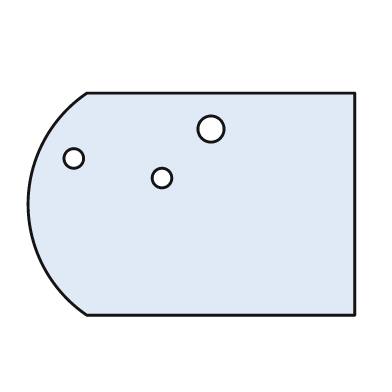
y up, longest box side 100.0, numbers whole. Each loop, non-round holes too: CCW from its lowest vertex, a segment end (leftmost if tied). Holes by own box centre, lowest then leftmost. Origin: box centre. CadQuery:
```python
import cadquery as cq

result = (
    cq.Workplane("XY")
    .moveTo(-32.0, -34.0)
    .lineTo(50.0, -34.0)
    .lineTo(50.0, 34.0)
    .lineTo(-32.0, 34.0)
    .threePointArc((-50.0, 0.0), (-32.0, -34.0))
    .close()
    .moveTo(-9.0, 8.0)
    .circle(3.0)
    .moveTo(-36.0, 14.0)
    .circle(3.0)
    .moveTo(6.0, 23.0)
    .circle(4.0)
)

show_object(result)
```